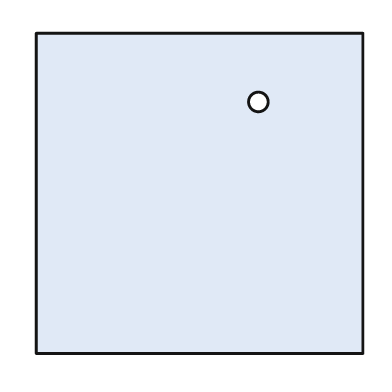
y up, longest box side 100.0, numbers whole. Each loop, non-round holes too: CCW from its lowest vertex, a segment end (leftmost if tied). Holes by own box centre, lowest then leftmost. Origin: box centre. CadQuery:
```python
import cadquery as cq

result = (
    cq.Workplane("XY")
    .moveTo(-50.0, -49.0)
    .lineTo(50.0, -49.0)
    .lineTo(50.0, 49.0)
    .lineTo(-50.0, 49.0)
    .close()
    .moveTo(18.0, 28.0)
    .circle(3.0)
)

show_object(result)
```